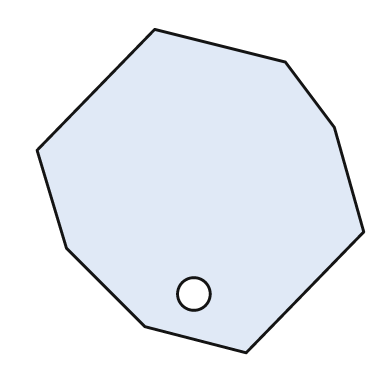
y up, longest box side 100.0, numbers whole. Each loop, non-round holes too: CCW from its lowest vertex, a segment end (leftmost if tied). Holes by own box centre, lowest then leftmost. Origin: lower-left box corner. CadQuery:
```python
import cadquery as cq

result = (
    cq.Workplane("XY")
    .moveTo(64.0, 0.0)
    .lineTo(100.0, 37.0)
    .lineTo(91.0, 69.0)
    .lineTo(76.0, 89.0)
    .lineTo(36.0, 99.0)
    .lineTo(0.0, 62.0)
    .lineTo(9.0, 32.0)
    .lineTo(33.0, 8.0)
    .close()
    .moveTo(48.0, 18.0)
    .circle(5.0)
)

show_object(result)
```